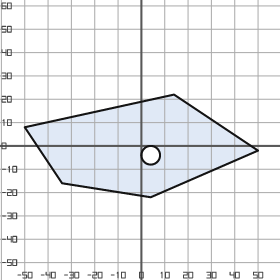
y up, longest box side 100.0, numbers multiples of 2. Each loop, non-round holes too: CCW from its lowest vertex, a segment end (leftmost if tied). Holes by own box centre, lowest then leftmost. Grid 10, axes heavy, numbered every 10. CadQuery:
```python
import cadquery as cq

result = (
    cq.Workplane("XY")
    .moveTo(4.0, -22.0)
    .lineTo(50.0, -2.0)
    .lineTo(14.0, 22.0)
    .lineTo(-50.0, 8.0)
    .lineTo(-34.0, -16.0)
    .close()
    .moveTo(4.0, -4.0)
    .circle(4.0)
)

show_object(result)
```